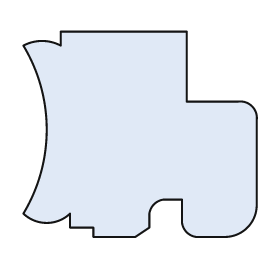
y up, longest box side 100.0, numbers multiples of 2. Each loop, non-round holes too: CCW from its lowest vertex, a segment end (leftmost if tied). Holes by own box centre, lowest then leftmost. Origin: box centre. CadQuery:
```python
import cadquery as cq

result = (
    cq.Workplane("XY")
    .moveTo(-20.0, -44.0)
    .lineTo(-2.0, -44.0)
    .lineTo(4.0, -40.0)
    .lineTo(4.0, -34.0)
    .threePointArc((6.0, -30.0), (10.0, -28.0))
    .lineTo(18.0, -28.0)
    .lineTo(18.0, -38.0)
    .threePointArc((20.0, -42.0), (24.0, -44.0))
    .lineTo(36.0, -44.0)
    .threePointArc((46.0, -40.0), (50.0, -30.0))
    .lineTo(50.0, 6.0)
    .threePointArc((48.0, 12.0), (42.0, 14.0))
    .lineTo(20.0, 14.0)
    .lineTo(20.0, 44.0)
    .lineTo(-34.0, 44.0)
    .lineTo(-34.0, 38.0)
    .threePointArc((-42.0, 40.0), (-50.0, 38.0))
    .threePointArc((-40.0, 2.0), (-50.0, -34.0))
    .threePointArc((-40.0, -38.0), (-30.0, -34.0))
    .lineTo(-30.0, -40.0)
    .lineTo(-20.0, -40.0)
    .close()
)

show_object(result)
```